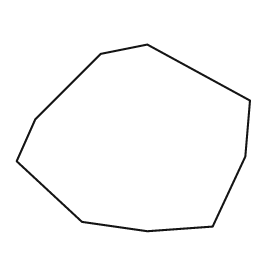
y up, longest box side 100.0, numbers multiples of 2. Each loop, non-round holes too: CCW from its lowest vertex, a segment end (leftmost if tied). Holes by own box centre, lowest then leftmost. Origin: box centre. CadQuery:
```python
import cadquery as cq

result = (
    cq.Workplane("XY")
    .moveTo(6.0, -40.0)
    .lineTo(34.0, -38.0)
    .lineTo(48.0, -8.0)
    .lineTo(50.0, 16.0)
    .lineTo(6.0, 40.0)
    .lineTo(-14.0, 36.0)
    .lineTo(-42.0, 8.0)
    .lineTo(-50.0, -10.0)
    .lineTo(-22.0, -36.0)
    .close()
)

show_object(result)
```